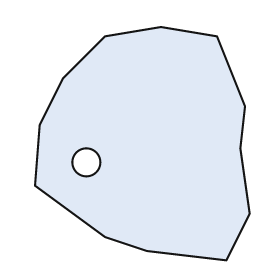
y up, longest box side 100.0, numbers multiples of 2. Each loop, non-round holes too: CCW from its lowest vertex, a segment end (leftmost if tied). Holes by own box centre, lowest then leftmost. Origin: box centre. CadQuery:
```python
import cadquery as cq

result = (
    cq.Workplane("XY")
    .moveTo(36.0, -50.0)
    .lineTo(46.0, -30.0)
    .lineTo(42.0, -2.0)
    .lineTo(44.0, 16.0)
    .lineTo(32.0, 46.0)
    .lineTo(8.0, 50.0)
    .lineTo(-16.0, 46.0)
    .lineTo(-34.0, 28.0)
    .lineTo(-44.0, 8.0)
    .lineTo(-46.0, -18.0)
    .lineTo(-16.0, -40.0)
    .lineTo(2.0, -46.0)
    .close()
    .moveTo(-24.0, -8.0)
    .circle(6.0)
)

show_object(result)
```